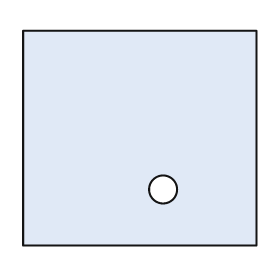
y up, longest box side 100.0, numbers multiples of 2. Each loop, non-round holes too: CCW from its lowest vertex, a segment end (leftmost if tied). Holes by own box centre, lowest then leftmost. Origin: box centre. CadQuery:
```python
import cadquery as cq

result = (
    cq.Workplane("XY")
    .moveTo(-50.0, -46.0)
    .lineTo(50.0, -46.0)
    .lineTo(50.0, 46.0)
    .lineTo(-50.0, 46.0)
    .close()
    .moveTo(10.0, -22.0)
    .circle(6.0)
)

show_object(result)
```